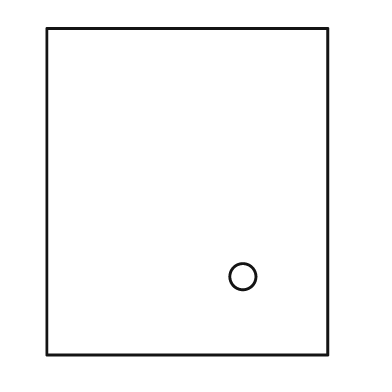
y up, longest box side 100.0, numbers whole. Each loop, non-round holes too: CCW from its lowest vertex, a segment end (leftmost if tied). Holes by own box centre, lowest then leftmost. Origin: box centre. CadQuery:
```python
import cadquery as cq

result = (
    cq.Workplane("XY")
    .moveTo(-43.0, -50.0)
    .lineTo(43.0, -50.0)
    .lineTo(43.0, 50.0)
    .lineTo(-43.0, 50.0)
    .close()
    .moveTo(17.0, -26.0)
    .circle(4.0)
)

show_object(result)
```